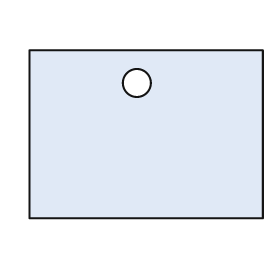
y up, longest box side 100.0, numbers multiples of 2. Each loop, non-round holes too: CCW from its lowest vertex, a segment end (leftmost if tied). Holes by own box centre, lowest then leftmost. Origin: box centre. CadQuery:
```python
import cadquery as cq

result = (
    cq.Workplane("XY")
    .moveTo(-50.0, -36.0)
    .lineTo(50.0, -36.0)
    .lineTo(50.0, 36.0)
    .lineTo(-50.0, 36.0)
    .close()
    .moveTo(-4.0, 22.0)
    .circle(6.0)
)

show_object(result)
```